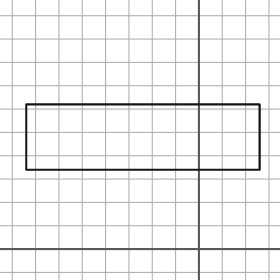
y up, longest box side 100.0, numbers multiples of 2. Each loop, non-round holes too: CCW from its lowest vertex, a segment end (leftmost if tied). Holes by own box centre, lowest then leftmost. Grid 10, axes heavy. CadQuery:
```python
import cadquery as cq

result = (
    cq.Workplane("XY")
    .moveTo(-74.0, 34.0)
    .lineTo(26.0, 34.0)
    .lineTo(26.0, 62.0)
    .lineTo(-74.0, 62.0)
    .close()
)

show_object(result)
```